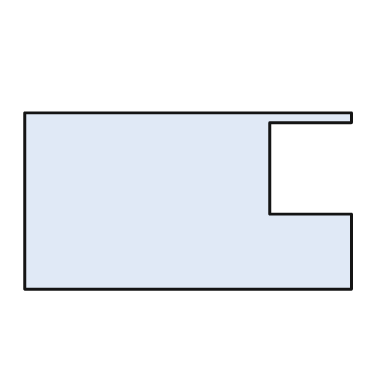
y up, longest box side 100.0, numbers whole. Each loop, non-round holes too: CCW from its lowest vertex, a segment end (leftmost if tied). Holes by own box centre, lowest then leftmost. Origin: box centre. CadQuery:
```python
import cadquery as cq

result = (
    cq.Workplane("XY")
    .moveTo(-50.0, -27.0)
    .lineTo(50.0, -27.0)
    .lineTo(50.0, -4.0)
    .lineTo(25.0, -4.0)
    .lineTo(25.0, 24.0)
    .lineTo(50.0, 24.0)
    .lineTo(50.0, 27.0)
    .lineTo(-50.0, 27.0)
    .close()
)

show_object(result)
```